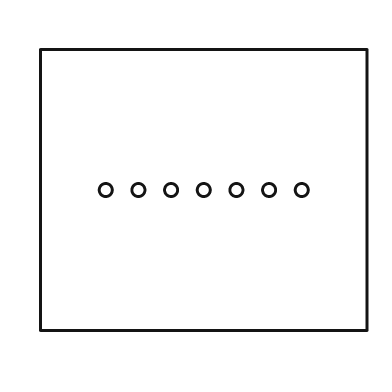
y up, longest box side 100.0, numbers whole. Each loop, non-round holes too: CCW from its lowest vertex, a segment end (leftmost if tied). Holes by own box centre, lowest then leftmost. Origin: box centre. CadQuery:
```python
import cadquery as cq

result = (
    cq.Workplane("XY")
    .moveTo(-50.0, -43.0)
    .lineTo(50.0, -43.0)
    .lineTo(50.0, 43.0)
    .lineTo(-50.0, 43.0)
    .close()
    .moveTo(-30.0, 0.0)
    .circle(2.0)
    .moveTo(-20.0, 0.0)
    .circle(2.0)
    .moveTo(-10.0, 0.0)
    .circle(2.0)
    .moveTo(0.0, 0.0)
    .circle(2.0)
    .moveTo(10.0, 0.0)
    .circle(2.0)
    .moveTo(20.0, 0.0)
    .circle(2.0)
    .moveTo(30.0, 0.0)
    .circle(2.0)
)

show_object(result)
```